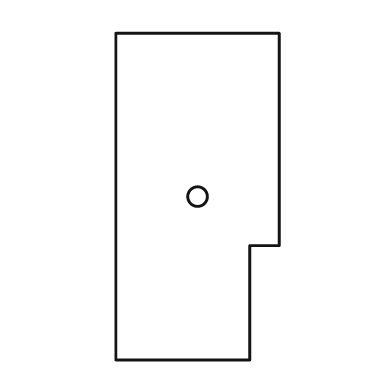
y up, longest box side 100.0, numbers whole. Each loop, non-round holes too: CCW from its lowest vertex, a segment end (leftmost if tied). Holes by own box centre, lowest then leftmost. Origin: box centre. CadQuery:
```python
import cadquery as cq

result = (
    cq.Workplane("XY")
    .moveTo(-25.0, -50.0)
    .lineTo(16.0, -50.0)
    .lineTo(16.0, -15.0)
    .lineTo(25.0, -15.0)
    .lineTo(25.0, 50.0)
    .lineTo(-25.0, 50.0)
    .close()
    .moveTo(0.0, 0.0)
    .circle(3.0)
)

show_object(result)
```